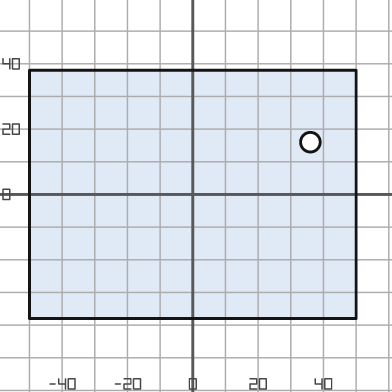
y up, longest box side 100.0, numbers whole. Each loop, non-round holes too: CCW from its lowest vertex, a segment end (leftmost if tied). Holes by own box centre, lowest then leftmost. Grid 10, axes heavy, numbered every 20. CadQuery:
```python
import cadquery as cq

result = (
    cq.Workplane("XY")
    .moveTo(-50.0, -38.0)
    .lineTo(50.0, -38.0)
    .lineTo(50.0, 38.0)
    .lineTo(-50.0, 38.0)
    .close()
    .moveTo(36.0, 16.0)
    .circle(3.0)
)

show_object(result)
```